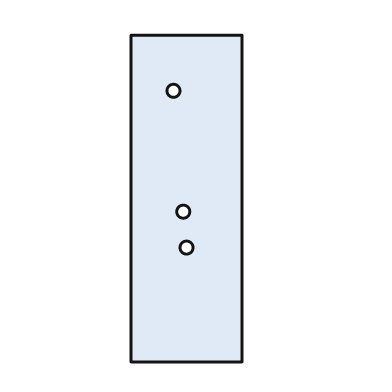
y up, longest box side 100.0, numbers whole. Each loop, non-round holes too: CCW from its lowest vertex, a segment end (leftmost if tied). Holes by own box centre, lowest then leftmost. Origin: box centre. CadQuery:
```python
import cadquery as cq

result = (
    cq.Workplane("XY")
    .moveTo(-17.0, -50.0)
    .lineTo(17.0, -50.0)
    .lineTo(17.0, 50.0)
    .lineTo(-17.0, 50.0)
    .close()
    .moveTo(0.0, -15.0)
    .circle(2.0)
    .moveTo(-1.0, -4.0)
    .circle(2.0)
    .moveTo(-4.0, 33.0)
    .circle(2.0)
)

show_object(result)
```